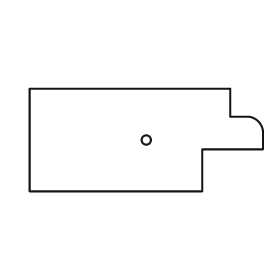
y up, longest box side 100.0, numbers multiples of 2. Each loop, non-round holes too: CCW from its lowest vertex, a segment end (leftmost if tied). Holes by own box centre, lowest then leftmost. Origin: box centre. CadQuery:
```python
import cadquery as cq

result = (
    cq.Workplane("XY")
    .moveTo(-50.0, -22.0)
    .lineTo(24.0, -22.0)
    .lineTo(24.0, -4.0)
    .lineTo(50.0, -4.0)
    .lineTo(50.0, 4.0)
    .threePointArc((48.0, 8.0), (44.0, 10.0))
    .lineTo(36.0, 10.0)
    .lineTo(36.0, 22.0)
    .lineTo(-50.0, 22.0)
    .close()
    .moveTo(0.0, 0.0)
    .circle(2.0)
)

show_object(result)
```